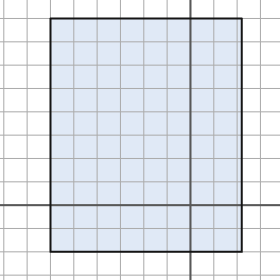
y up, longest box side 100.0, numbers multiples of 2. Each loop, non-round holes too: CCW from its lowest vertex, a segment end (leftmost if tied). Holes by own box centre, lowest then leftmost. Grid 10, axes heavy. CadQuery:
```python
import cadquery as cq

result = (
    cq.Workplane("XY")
    .moveTo(-60.0, -20.0)
    .lineTo(22.0, -20.0)
    .lineTo(22.0, 80.0)
    .lineTo(-60.0, 80.0)
    .close()
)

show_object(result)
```